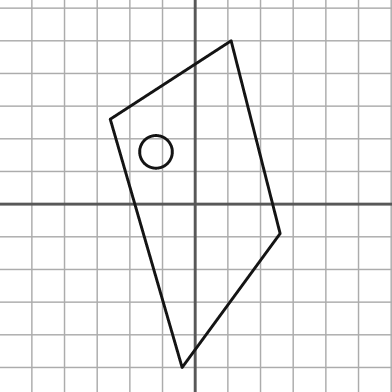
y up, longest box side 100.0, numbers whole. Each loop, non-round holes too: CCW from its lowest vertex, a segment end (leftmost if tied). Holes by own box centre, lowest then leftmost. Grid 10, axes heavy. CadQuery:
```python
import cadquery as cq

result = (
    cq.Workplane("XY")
    .moveTo(-4.0, -50.0)
    .lineTo(26.0, -9.0)
    .lineTo(11.0, 50.0)
    .lineTo(-26.0, 26.0)
    .close()
    .moveTo(-12.0, 16.0)
    .circle(5.0)
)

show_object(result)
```